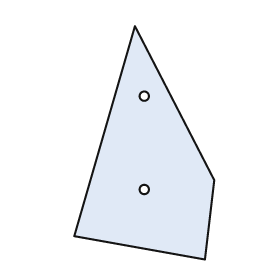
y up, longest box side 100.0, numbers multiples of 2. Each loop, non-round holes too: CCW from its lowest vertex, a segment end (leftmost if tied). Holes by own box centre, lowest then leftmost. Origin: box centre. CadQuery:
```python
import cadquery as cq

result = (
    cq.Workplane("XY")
    .moveTo(26.0, -50.0)
    .lineTo(30.0, -16.0)
    .lineTo(-4.0, 50.0)
    .lineTo(-30.0, -40.0)
    .close()
    .moveTo(0.0, -20.0)
    .circle(2.0)
    .moveTo(0.0, 20.0)
    .circle(2.0)
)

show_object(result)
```